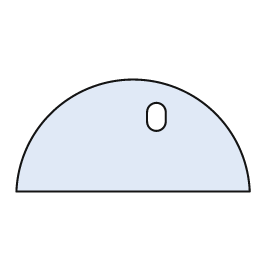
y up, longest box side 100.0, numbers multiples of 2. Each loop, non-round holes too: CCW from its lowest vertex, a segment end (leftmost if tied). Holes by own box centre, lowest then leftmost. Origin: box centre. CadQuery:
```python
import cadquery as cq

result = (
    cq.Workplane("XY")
    .moveTo(-50.0, -24.0)
    .lineTo(50.0, -24.0)
    .threePointArc((0.0, 24.0), (-50.0, -24.0))
    .close()
    .moveTo(6.0, 6.0)
    .threePointArc((10.0, 2.0), (14.0, 6.0))
    .lineTo(14.0, 10.0)
    .threePointArc((10.0, 14.0), (6.0, 10.0))
    .close()
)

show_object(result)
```